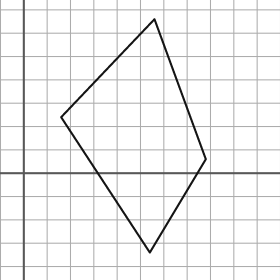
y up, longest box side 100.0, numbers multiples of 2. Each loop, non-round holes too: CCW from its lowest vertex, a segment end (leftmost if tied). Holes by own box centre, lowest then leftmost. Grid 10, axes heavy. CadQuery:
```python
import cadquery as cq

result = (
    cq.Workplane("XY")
    .moveTo(54.0, -34.0)
    .lineTo(78.0, 6.0)
    .lineTo(56.0, 66.0)
    .lineTo(16.0, 24.0)
    .close()
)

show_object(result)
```